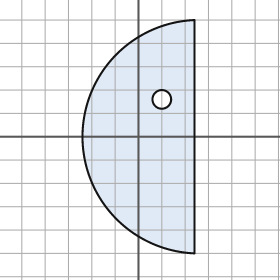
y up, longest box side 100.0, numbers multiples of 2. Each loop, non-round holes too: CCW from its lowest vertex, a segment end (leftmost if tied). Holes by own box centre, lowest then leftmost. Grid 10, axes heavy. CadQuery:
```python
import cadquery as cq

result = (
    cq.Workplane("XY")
    .moveTo(24.0, -50.0)
    .lineTo(24.0, 50.0)
    .threePointArc((-24.0, 0.0), (24.0, -50.0))
    .close()
    .moveTo(10.0, 16.0)
    .circle(4.0)
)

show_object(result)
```